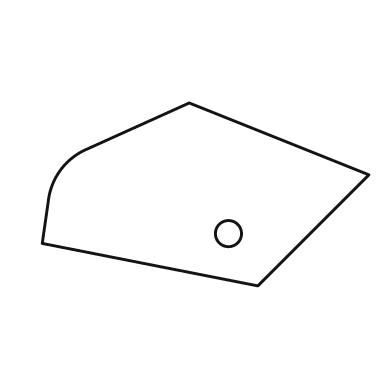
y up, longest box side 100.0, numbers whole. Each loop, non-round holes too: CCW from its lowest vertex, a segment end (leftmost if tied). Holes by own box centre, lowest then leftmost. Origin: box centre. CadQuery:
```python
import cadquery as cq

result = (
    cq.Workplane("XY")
    .moveTo(16.0, -28.0)
    .lineTo(50.0, 6.0)
    .lineTo(-5.0, 28.0)
    .lineTo(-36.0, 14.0)
    .threePointArc((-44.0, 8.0), (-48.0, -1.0))
    .lineTo(-50.0, -15.0)
    .close()
    .moveTo(7.0, -12.0)
    .circle(4.0)
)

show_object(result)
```